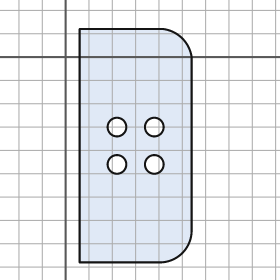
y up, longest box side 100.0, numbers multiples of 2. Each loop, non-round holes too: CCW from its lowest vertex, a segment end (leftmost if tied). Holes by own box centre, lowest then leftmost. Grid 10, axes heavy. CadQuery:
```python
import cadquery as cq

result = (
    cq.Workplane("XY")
    .moveTo(6.0, -88.0)
    .lineTo(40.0, -88.0)
    .threePointArc((50.0, -84.0), (54.0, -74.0))
    .lineTo(54.0, 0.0)
    .threePointArc((50.0, 8.0), (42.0, 12.0))
    .lineTo(6.0, 12.0)
    .close()
    .moveTo(22.0, -46.0)
    .circle(4.0)
    .moveTo(38.0, -46.0)
    .circle(4.0)
    .moveTo(22.0, -30.0)
    .circle(4.0)
    .moveTo(38.0, -30.0)
    .circle(4.0)
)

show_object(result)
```